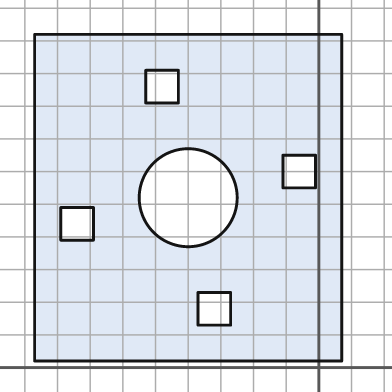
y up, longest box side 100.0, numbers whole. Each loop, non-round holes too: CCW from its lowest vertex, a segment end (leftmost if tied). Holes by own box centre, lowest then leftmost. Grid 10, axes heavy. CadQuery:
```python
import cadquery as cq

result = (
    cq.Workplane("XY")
    .moveTo(-87.0, 2.0)
    .lineTo(7.0, 2.0)
    .lineTo(7.0, 102.0)
    .lineTo(-87.0, 102.0)
    .close()
    .moveTo(-37.0, 13.0)
    .lineTo(-27.0, 13.0)
    .lineTo(-27.0, 23.0)
    .lineTo(-37.0, 23.0)
    .close()
    .moveTo(-79.0, 39.0)
    .lineTo(-69.0, 39.0)
    .lineTo(-69.0, 49.0)
    .lineTo(-79.0, 49.0)
    .close()
    .moveTo(-40.0, 52.0)
    .circle(15.0)
    .moveTo(-11.0, 55.0)
    .lineTo(-1.0, 55.0)
    .lineTo(-1.0, 65.0)
    .lineTo(-11.0, 65.0)
    .close()
    .moveTo(-53.0, 81.0)
    .lineTo(-43.0, 81.0)
    .lineTo(-43.0, 91.0)
    .lineTo(-53.0, 91.0)
    .close()
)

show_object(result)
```